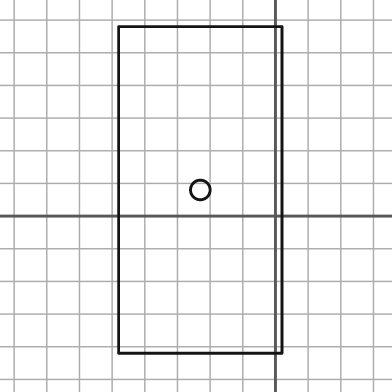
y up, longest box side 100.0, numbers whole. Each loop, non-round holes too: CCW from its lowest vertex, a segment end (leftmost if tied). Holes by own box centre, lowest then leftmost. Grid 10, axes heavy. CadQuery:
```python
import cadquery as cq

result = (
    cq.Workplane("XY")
    .moveTo(-48.0, -42.0)
    .lineTo(2.0, -42.0)
    .lineTo(2.0, 58.0)
    .lineTo(-48.0, 58.0)
    .close()
    .moveTo(-23.0, 8.0)
    .circle(3.0)
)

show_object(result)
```